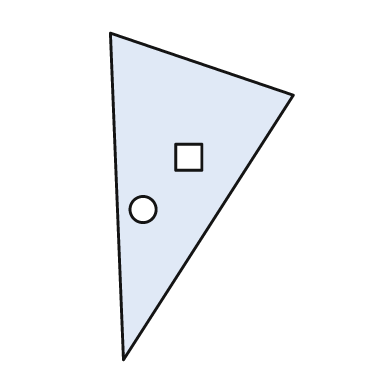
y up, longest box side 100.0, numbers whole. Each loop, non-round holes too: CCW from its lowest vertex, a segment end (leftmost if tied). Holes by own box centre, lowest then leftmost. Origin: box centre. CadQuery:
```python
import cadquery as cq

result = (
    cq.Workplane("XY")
    .moveTo(-24.0, -50.0)
    .lineTo(28.0, 31.0)
    .lineTo(-28.0, 50.0)
    .close()
    .moveTo(-18.0, -4.0)
    .circle(4.0)
    .moveTo(-8.0, 8.0)
    .lineTo(0.0, 8.0)
    .lineTo(0.0, 16.0)
    .lineTo(-8.0, 16.0)
    .close()
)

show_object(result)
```